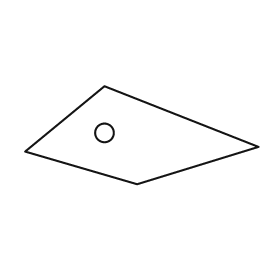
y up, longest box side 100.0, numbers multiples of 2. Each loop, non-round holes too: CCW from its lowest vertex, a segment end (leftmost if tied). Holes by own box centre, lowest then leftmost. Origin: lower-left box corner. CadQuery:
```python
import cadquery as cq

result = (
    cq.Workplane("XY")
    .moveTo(48.0, 0.0)
    .lineTo(100.0, 16.0)
    .lineTo(34.0, 42.0)
    .lineTo(0.0, 14.0)
    .close()
    .moveTo(34.0, 22.0)
    .circle(4.0)
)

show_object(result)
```